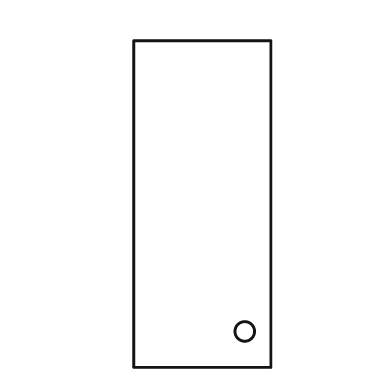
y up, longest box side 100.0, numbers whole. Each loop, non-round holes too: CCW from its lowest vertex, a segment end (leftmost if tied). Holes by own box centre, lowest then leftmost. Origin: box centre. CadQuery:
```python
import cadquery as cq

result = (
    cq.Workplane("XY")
    .moveTo(-21.0, -50.0)
    .lineTo(21.0, -50.0)
    .lineTo(21.0, 50.0)
    .lineTo(-21.0, 50.0)
    .close()
    .moveTo(13.0, -39.0)
    .circle(3.0)
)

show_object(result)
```